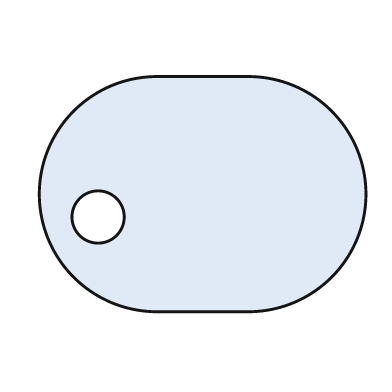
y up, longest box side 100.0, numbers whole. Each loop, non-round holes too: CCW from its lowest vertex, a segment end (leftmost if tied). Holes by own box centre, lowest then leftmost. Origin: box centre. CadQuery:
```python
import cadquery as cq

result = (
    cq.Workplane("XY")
    .moveTo(-14.0, -36.0)
    .lineTo(14.0, -36.0)
    .threePointArc((50.0, 0.0), (14.0, 36.0))
    .lineTo(-14.0, 36.0)
    .threePointArc((-50.0, 0.0), (-14.0, -36.0))
    .close()
    .moveTo(-32.0, -7.0)
    .circle(8.0)
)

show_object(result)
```